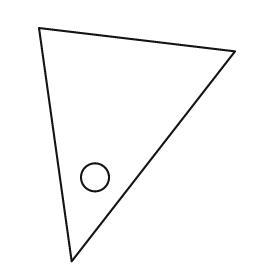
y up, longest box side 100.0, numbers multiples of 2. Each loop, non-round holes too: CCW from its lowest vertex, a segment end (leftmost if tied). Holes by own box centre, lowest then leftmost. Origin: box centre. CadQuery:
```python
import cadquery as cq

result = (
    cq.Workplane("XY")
    .moveTo(-28.0, -50.0)
    .lineTo(42.0, 40.0)
    .lineTo(-42.0, 50.0)
    .close()
    .moveTo(-18.0, -14.0)
    .circle(6.0)
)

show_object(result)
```